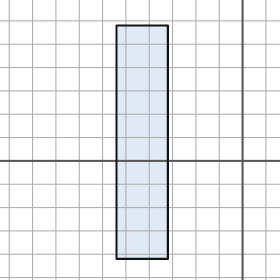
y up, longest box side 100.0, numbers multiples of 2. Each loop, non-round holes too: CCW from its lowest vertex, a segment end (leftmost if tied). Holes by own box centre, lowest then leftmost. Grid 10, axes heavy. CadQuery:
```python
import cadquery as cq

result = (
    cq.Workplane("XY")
    .moveTo(-54.0, -42.0)
    .lineTo(-32.0, -42.0)
    .lineTo(-32.0, 58.0)
    .lineTo(-54.0, 58.0)
    .close()
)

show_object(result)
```